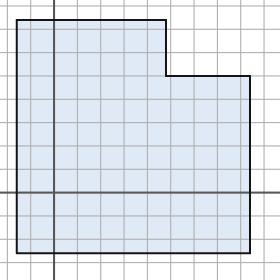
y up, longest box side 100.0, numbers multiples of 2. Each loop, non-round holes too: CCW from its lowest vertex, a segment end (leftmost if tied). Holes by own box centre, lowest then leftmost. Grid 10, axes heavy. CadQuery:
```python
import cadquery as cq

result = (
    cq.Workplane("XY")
    .moveTo(-16.0, -26.0)
    .lineTo(84.0, -26.0)
    .lineTo(84.0, 50.0)
    .lineTo(48.0, 50.0)
    .lineTo(48.0, 74.0)
    .lineTo(-16.0, 74.0)
    .close()
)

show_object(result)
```